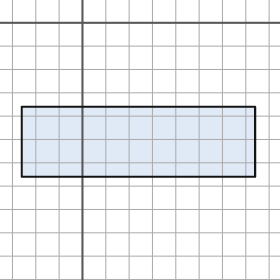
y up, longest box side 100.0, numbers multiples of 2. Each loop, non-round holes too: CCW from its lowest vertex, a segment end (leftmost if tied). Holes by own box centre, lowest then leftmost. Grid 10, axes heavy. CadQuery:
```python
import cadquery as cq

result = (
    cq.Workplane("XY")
    .moveTo(-26.0, -66.0)
    .lineTo(74.0, -66.0)
    .lineTo(74.0, -36.0)
    .lineTo(-26.0, -36.0)
    .close()
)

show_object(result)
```